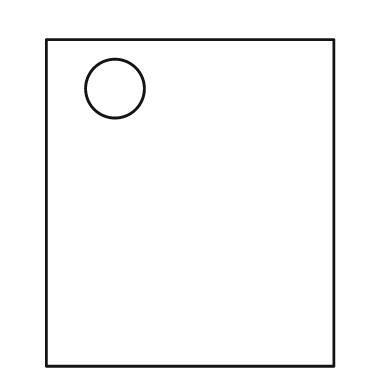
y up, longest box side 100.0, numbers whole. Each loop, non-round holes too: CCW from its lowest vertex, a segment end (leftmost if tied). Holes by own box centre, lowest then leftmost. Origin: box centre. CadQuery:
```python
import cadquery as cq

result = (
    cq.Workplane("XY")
    .moveTo(-44.0, -50.0)
    .lineTo(44.0, -50.0)
    .lineTo(44.0, 50.0)
    .lineTo(-44.0, 50.0)
    .close()
    .moveTo(-23.0, 35.0)
    .circle(9.0)
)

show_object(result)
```